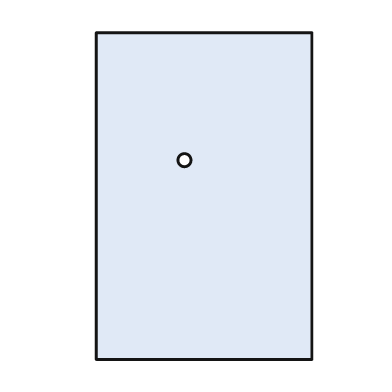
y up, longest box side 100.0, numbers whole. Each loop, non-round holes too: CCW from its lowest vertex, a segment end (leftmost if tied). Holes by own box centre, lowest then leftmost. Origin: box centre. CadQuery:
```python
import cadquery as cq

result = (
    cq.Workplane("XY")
    .moveTo(-33.0, -50.0)
    .lineTo(33.0, -50.0)
    .lineTo(33.0, 50.0)
    .lineTo(-33.0, 50.0)
    .close()
    .moveTo(-6.0, 11.0)
    .circle(2.0)
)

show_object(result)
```